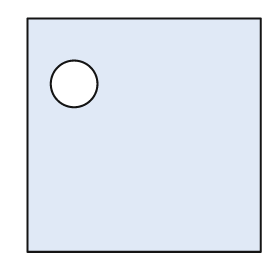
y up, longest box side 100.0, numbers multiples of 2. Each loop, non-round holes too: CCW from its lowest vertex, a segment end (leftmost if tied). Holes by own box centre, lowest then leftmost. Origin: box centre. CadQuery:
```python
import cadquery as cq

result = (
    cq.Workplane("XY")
    .moveTo(-50.0, -50.0)
    .lineTo(50.0, -50.0)
    .lineTo(50.0, 50.0)
    .lineTo(-50.0, 50.0)
    .close()
    .moveTo(-30.0, 22.0)
    .circle(10.0)
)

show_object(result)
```